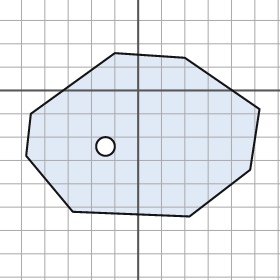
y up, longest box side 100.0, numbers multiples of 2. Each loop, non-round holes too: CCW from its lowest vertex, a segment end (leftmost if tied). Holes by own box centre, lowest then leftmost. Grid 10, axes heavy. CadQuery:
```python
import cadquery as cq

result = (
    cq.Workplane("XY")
    .moveTo(22.0, -54.0)
    .lineTo(48.0, -34.0)
    .lineTo(52.0, -8.0)
    .lineTo(20.0, 14.0)
    .lineTo(-10.0, 16.0)
    .lineTo(-46.0, -10.0)
    .lineTo(-48.0, -28.0)
    .lineTo(-28.0, -52.0)
    .close()
    .moveTo(-14.0, -24.0)
    .circle(4.0)
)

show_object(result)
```